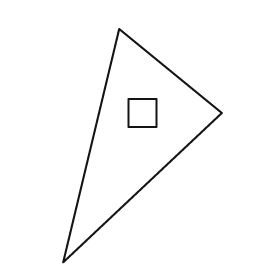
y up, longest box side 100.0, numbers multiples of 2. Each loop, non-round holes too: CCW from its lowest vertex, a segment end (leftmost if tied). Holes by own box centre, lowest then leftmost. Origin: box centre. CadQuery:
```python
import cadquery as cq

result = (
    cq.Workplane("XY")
    .moveTo(-34.0, -50.0)
    .lineTo(34.0, 14.0)
    .lineTo(-10.0, 50.0)
    .close()
    .moveTo(-6.0, 8.0)
    .lineTo(6.0, 8.0)
    .lineTo(6.0, 20.0)
    .lineTo(-6.0, 20.0)
    .close()
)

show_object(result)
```